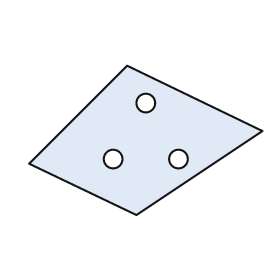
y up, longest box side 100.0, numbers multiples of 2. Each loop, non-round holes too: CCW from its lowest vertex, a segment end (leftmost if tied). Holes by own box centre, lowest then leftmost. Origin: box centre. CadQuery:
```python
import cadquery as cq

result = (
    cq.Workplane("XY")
    .moveTo(-4.0, -32.0)
    .lineTo(50.0, 4.0)
    .lineTo(-8.0, 32.0)
    .lineTo(-50.0, -10.0)
    .close()
    .moveTo(-14.0, -8.0)
    .circle(4.0)
    .moveTo(14.0, -8.0)
    .circle(4.0)
    .moveTo(0.0, 16.0)
    .circle(4.0)
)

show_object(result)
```